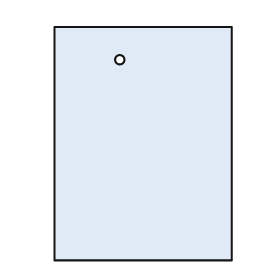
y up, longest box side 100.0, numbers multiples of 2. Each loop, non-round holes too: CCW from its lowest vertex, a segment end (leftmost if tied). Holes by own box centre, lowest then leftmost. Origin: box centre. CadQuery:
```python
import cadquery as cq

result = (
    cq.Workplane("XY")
    .moveTo(-38.0, -50.0)
    .lineTo(38.0, -50.0)
    .lineTo(38.0, 50.0)
    .lineTo(-38.0, 50.0)
    .close()
    .moveTo(-10.0, 36.0)
    .circle(2.0)
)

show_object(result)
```